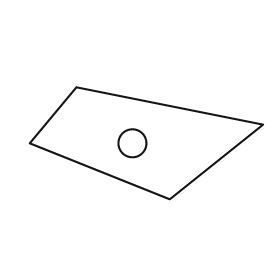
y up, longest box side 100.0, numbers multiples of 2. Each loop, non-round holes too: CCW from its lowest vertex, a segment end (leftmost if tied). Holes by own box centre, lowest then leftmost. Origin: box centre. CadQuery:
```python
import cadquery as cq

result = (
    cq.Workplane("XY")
    .moveTo(10.0, -24.0)
    .lineTo(50.0, 8.0)
    .lineTo(-30.0, 24.0)
    .lineTo(-50.0, 0.0)
    .close()
    .moveTo(-6.0, 0.0)
    .circle(6.0)
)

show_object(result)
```